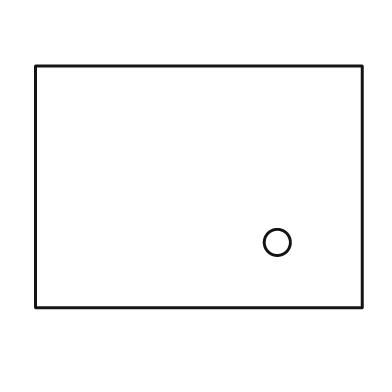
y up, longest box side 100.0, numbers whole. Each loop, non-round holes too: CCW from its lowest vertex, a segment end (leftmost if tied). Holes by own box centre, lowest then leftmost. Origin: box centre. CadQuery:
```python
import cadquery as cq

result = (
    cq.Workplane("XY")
    .moveTo(-50.0, -37.0)
    .lineTo(50.0, -37.0)
    .lineTo(50.0, 37.0)
    .lineTo(-50.0, 37.0)
    .close()
    .moveTo(24.0, -17.0)
    .circle(4.0)
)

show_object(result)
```